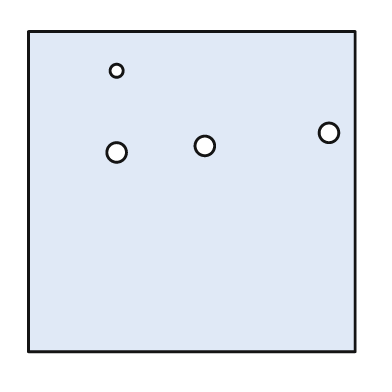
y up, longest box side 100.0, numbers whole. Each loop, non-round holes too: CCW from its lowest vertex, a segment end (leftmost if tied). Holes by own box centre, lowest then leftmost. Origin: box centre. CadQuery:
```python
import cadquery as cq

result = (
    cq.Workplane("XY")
    .moveTo(-50.0, -49.0)
    .lineTo(50.0, -49.0)
    .lineTo(50.0, 49.0)
    .lineTo(-50.0, 49.0)
    .close()
    .moveTo(-23.0, 12.0)
    .circle(3.0)
    .moveTo(4.0, 14.0)
    .circle(3.0)
    .moveTo(42.0, 18.0)
    .circle(3.0)
    .moveTo(-23.0, 37.0)
    .circle(2.0)
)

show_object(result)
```